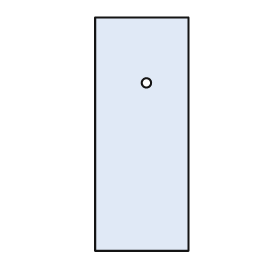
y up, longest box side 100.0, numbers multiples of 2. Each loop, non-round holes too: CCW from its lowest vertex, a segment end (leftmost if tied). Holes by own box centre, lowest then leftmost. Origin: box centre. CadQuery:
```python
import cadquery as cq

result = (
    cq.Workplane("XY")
    .moveTo(-20.0, -50.0)
    .lineTo(20.0, -50.0)
    .lineTo(20.0, 50.0)
    .lineTo(-20.0, 50.0)
    .close()
    .moveTo(2.0, 22.0)
    .circle(2.0)
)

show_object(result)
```